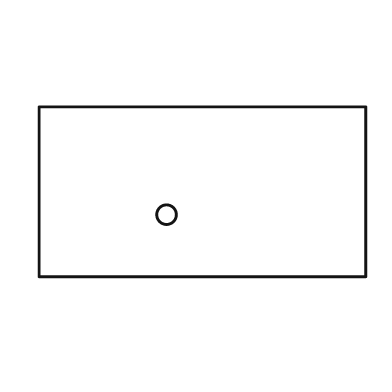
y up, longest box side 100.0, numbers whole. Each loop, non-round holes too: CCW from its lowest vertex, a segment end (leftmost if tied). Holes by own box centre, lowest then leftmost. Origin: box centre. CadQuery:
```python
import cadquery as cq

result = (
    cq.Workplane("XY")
    .moveTo(-50.0, -26.0)
    .lineTo(50.0, -26.0)
    .lineTo(50.0, 26.0)
    .lineTo(-50.0, 26.0)
    .close()
    .moveTo(-11.0, -7.0)
    .circle(3.0)
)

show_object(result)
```